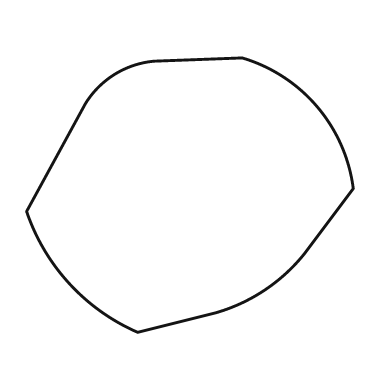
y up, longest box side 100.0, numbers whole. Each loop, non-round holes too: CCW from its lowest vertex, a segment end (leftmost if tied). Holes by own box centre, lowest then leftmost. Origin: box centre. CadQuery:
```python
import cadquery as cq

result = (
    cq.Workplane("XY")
    .moveTo(-16.0, -42.0)
    .lineTo(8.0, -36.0)
    .threePointArc((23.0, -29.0), (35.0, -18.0))
    .lineTo(50.0, 2.0)
    .threePointArc((39.0, 27.0), (16.0, 42.0))
    .lineTo(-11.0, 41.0)
    .threePointArc((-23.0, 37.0), (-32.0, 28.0))
    .lineTo(-50.0, -5.0)
    .threePointArc((-37.0, -27.0), (-16.0, -42.0))
    .close()
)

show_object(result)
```